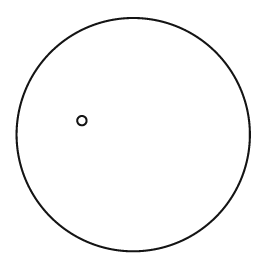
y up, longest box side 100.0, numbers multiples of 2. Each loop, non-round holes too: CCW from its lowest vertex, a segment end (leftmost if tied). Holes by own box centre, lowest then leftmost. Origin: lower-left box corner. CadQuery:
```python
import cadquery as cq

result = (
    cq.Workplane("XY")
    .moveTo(50.0, 50.0)
    .circle(50.0)
    .moveTo(28.0, 56.0)
    .circle(2.0)
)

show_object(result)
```